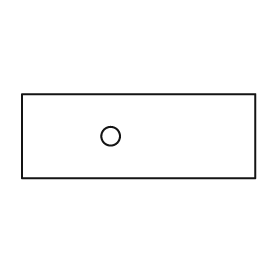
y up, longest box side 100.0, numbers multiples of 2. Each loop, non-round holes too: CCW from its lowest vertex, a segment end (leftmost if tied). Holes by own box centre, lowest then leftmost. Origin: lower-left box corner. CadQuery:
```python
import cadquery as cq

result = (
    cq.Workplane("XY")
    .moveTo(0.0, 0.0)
    .lineTo(100.0, 0.0)
    .lineTo(100.0, 36.0)
    .lineTo(0.0, 36.0)
    .close()
    .moveTo(38.0, 18.0)
    .circle(4.0)
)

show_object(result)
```